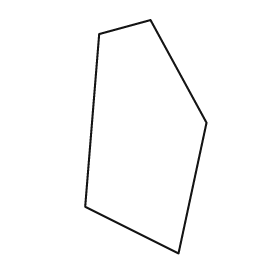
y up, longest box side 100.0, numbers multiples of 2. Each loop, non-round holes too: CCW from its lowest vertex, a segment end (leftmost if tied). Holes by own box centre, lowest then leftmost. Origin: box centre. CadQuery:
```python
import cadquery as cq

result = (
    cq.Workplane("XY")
    .moveTo(14.0, -50.0)
    .lineTo(26.0, 6.0)
    .lineTo(2.0, 50.0)
    .lineTo(-20.0, 44.0)
    .lineTo(-26.0, -30.0)
    .close()
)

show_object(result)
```